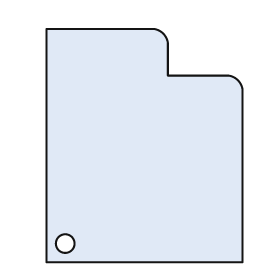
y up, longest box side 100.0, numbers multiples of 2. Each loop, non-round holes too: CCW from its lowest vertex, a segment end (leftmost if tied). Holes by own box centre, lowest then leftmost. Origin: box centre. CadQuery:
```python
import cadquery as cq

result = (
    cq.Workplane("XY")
    .moveTo(-42.0, -50.0)
    .lineTo(42.0, -50.0)
    .lineTo(42.0, 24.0)
    .threePointArc((40.0, 28.0), (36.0, 30.0))
    .lineTo(10.0, 30.0)
    .lineTo(10.0, 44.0)
    .threePointArc((8.0, 48.0), (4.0, 50.0))
    .lineTo(-42.0, 50.0)
    .close()
    .moveTo(-34.0, -42.0)
    .circle(4.0)
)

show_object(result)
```